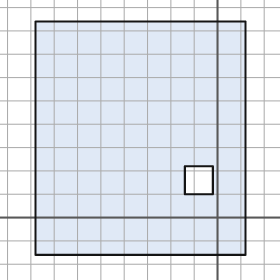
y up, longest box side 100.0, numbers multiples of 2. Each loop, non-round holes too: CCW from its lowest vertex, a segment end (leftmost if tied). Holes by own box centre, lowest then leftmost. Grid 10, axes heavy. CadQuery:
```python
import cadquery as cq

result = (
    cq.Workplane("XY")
    .moveTo(-78.0, -16.0)
    .lineTo(12.0, -16.0)
    .lineTo(12.0, 84.0)
    .lineTo(-78.0, 84.0)
    .close()
    .moveTo(-14.0, 10.0)
    .lineTo(-2.0, 10.0)
    .lineTo(-2.0, 22.0)
    .lineTo(-14.0, 22.0)
    .close()
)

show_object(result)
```